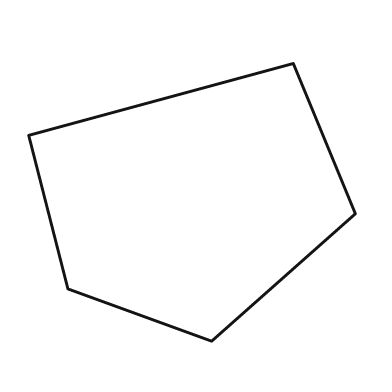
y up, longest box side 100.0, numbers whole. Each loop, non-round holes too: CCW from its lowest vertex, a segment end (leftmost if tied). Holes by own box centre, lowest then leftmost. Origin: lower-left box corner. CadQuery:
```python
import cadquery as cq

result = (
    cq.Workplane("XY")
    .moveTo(56.0, 0.0)
    .lineTo(100.0, 39.0)
    .lineTo(81.0, 85.0)
    .lineTo(0.0, 63.0)
    .lineTo(12.0, 16.0)
    .close()
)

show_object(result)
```